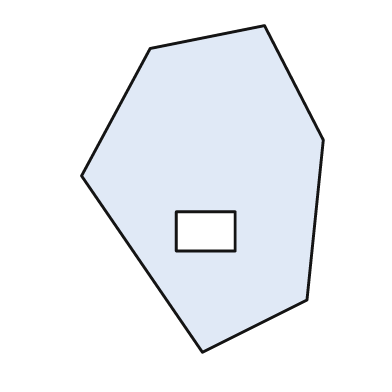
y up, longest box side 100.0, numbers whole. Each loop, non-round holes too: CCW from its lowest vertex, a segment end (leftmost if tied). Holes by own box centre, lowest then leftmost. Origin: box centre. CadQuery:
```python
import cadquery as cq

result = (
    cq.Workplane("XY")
    .moveTo(0.0, -50.0)
    .lineTo(32.0, -34.0)
    .lineTo(37.0, 15.0)
    .lineTo(19.0, 50.0)
    .lineTo(-16.0, 43.0)
    .lineTo(-37.0, 4.0)
    .close()
    .moveTo(-8.0, -19.0)
    .lineTo(10.0, -19.0)
    .lineTo(10.0, -7.0)
    .lineTo(-8.0, -7.0)
    .close()
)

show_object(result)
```